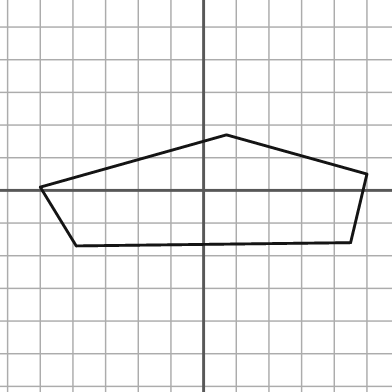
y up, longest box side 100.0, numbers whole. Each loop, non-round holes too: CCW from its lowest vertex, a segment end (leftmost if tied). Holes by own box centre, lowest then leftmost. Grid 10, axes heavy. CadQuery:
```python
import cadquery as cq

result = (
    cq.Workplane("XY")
    .moveTo(-39.0, -17.0)
    .lineTo(45.0, -16.0)
    .lineTo(50.0, 5.0)
    .lineTo(7.0, 17.0)
    .lineTo(-50.0, 1.0)
    .close()
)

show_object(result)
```